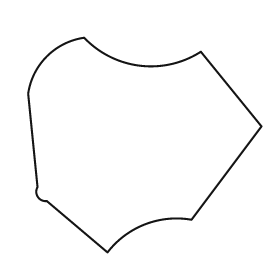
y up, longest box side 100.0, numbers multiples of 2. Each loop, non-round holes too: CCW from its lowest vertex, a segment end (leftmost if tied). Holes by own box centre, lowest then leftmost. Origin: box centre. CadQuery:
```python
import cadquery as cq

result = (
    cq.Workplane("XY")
    .moveTo(-16.0, -46.0)
    .threePointArc((0.0, -34.0), (20.0, -32.0))
    .lineTo(50.0, 8.0)
    .lineTo(24.0, 40.0)
    .threePointArc((-2.0, 34.0), (-26.0, 46.0))
    .threePointArc((-42.0, 38.0), (-50.0, 22.0))
    .lineTo(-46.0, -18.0)
    .threePointArc((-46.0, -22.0), (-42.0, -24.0))
    .close()
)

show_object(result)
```